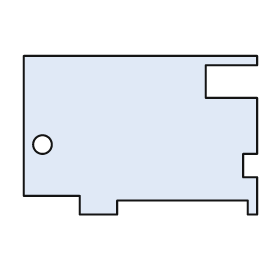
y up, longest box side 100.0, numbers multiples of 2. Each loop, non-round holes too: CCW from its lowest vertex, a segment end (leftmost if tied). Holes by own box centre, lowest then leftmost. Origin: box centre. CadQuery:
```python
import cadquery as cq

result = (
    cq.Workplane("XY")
    .moveTo(-26.0, -34.0)
    .lineTo(-10.0, -34.0)
    .lineTo(-10.0, -28.0)
    .lineTo(46.0, -28.0)
    .lineTo(46.0, -34.0)
    .lineTo(50.0, -34.0)
    .lineTo(50.0, -18.0)
    .lineTo(44.0, -18.0)
    .lineTo(44.0, -8.0)
    .lineTo(50.0, -8.0)
    .lineTo(50.0, 16.0)
    .lineTo(28.0, 16.0)
    .lineTo(28.0, 30.0)
    .lineTo(50.0, 30.0)
    .lineTo(50.0, 34.0)
    .lineTo(-50.0, 34.0)
    .lineTo(-50.0, -26.0)
    .lineTo(-26.0, -26.0)
    .close()
    .moveTo(-42.0, -4.0)
    .circle(4.0)
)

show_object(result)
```